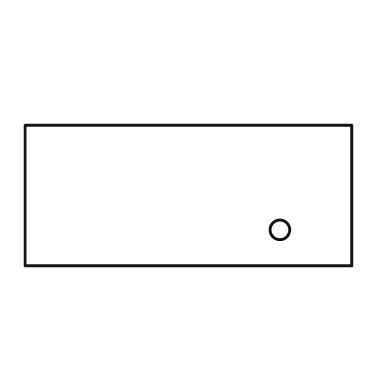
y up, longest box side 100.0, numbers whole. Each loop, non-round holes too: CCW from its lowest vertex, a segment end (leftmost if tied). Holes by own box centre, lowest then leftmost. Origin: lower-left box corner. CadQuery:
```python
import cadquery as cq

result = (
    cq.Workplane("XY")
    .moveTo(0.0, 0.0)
    .lineTo(100.0, 0.0)
    .lineTo(100.0, 43.0)
    .lineTo(0.0, 43.0)
    .close()
    .moveTo(78.0, 11.0)
    .circle(3.0)
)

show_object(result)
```